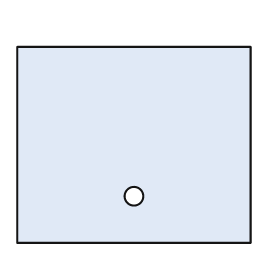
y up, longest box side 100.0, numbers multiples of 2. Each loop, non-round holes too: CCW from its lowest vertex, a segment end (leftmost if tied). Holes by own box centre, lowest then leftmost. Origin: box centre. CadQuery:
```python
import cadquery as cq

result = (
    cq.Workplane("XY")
    .moveTo(-50.0, -42.0)
    .lineTo(50.0, -42.0)
    .lineTo(50.0, 42.0)
    .lineTo(-50.0, 42.0)
    .close()
    .moveTo(0.0, -22.0)
    .circle(4.0)
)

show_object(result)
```